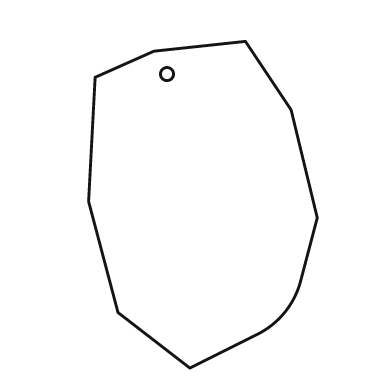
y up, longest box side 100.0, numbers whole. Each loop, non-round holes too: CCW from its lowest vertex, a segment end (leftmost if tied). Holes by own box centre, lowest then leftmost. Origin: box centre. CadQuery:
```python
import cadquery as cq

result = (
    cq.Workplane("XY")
    .moveTo(-4.0, -50.0)
    .lineTo(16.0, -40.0)
    .threePointArc((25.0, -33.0), (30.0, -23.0))
    .lineTo(35.0, -4.0)
    .lineTo(27.0, 29.0)
    .lineTo(13.0, 50.0)
    .lineTo(-15.0, 47.0)
    .lineTo(-33.0, 39.0)
    .lineTo(-35.0, 1.0)
    .lineTo(-26.0, -33.0)
    .close()
    .moveTo(-11.0, 40.0)
    .circle(2.0)
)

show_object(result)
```